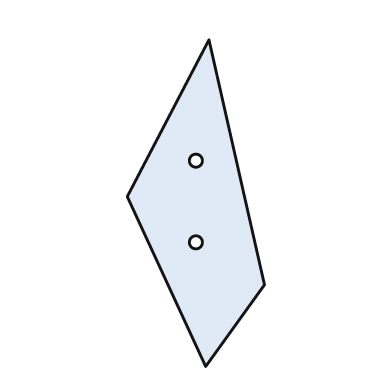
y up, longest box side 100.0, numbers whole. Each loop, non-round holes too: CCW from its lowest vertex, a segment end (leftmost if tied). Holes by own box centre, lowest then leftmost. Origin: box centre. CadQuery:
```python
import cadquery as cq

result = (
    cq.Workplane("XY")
    .moveTo(3.0, -50.0)
    .lineTo(21.0, -25.0)
    .lineTo(4.0, 50.0)
    .lineTo(-21.0, 2.0)
    .close()
    .moveTo(0.0, -12.0)
    .circle(2.0)
    .moveTo(0.0, 13.0)
    .circle(2.0)
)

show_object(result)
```